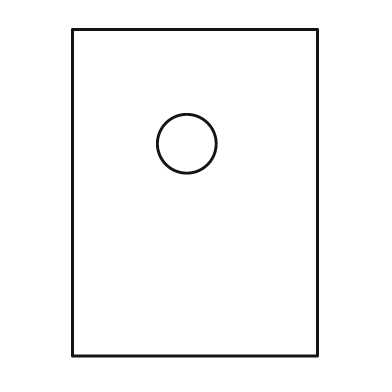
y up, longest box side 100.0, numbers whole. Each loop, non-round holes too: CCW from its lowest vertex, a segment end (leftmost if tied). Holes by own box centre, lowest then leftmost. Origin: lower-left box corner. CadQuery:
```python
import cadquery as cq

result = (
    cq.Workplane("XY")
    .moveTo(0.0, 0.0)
    .lineTo(75.0, 0.0)
    .lineTo(75.0, 100.0)
    .lineTo(0.0, 100.0)
    .close()
    .moveTo(35.0, 65.0)
    .circle(9.0)
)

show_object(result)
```